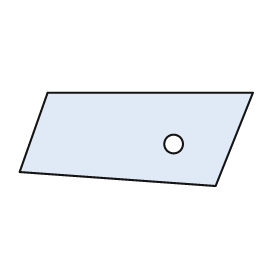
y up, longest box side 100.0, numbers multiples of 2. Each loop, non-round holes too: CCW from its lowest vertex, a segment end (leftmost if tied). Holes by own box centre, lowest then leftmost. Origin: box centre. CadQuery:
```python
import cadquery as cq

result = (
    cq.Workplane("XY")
    .moveTo(34.0, -20.0)
    .lineTo(50.0, 20.0)
    .lineTo(-38.0, 20.0)
    .lineTo(-50.0, -14.0)
    .close()
    .moveTo(16.0, -2.0)
    .circle(4.0)
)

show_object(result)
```